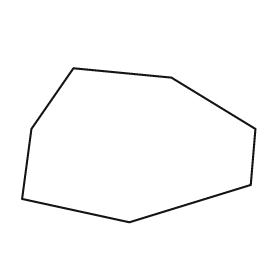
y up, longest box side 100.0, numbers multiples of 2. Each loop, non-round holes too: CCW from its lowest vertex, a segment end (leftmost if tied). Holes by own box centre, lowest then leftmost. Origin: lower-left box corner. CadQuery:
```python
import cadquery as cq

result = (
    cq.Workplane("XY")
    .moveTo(46.0, 0.0)
    .lineTo(98.0, 16.0)
    .lineTo(100.0, 40.0)
    .lineTo(64.0, 62.0)
    .lineTo(22.0, 66.0)
    .lineTo(4.0, 40.0)
    .lineTo(0.0, 10.0)
    .close()
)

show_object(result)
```